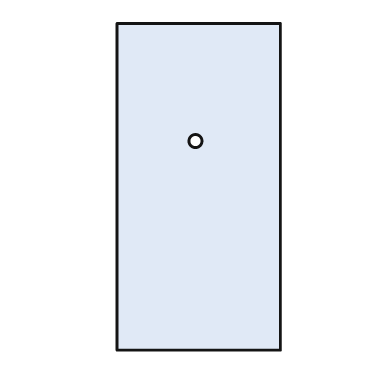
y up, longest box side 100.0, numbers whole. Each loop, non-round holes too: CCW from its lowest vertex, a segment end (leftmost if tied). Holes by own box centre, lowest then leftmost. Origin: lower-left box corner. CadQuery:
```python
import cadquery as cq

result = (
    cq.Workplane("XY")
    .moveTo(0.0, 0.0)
    .lineTo(50.0, 0.0)
    .lineTo(50.0, 100.0)
    .lineTo(0.0, 100.0)
    .close()
    .moveTo(24.0, 64.0)
    .circle(2.0)
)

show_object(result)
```